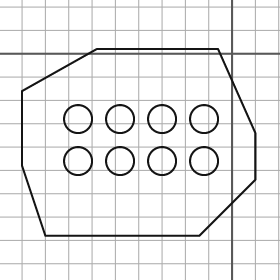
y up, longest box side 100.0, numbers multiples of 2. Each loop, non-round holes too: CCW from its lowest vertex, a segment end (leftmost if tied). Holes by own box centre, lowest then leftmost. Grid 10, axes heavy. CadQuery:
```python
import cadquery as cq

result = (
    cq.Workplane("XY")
    .moveTo(-80.0, -78.0)
    .lineTo(-14.0, -78.0)
    .lineTo(10.0, -54.0)
    .lineTo(10.0, -34.0)
    .lineTo(-6.0, 2.0)
    .lineTo(-58.0, 2.0)
    .lineTo(-90.0, -16.0)
    .lineTo(-90.0, -48.0)
    .close()
    .moveTo(-66.0, -46.0)
    .circle(6.0)
    .moveTo(-48.0, -46.0)
    .circle(6.0)
    .moveTo(-30.0, -46.0)
    .circle(6.0)
    .moveTo(-12.0, -46.0)
    .circle(6.0)
    .moveTo(-66.0, -28.0)
    .circle(6.0)
    .moveTo(-48.0, -28.0)
    .circle(6.0)
    .moveTo(-30.0, -28.0)
    .circle(6.0)
    .moveTo(-12.0, -28.0)
    .circle(6.0)
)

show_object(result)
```